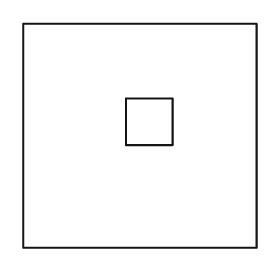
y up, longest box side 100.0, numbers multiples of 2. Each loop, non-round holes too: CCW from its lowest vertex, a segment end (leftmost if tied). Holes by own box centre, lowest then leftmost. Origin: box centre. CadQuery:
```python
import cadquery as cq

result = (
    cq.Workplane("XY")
    .moveTo(-50.0, -48.0)
    .lineTo(50.0, -48.0)
    .lineTo(50.0, 48.0)
    .lineTo(-50.0, 48.0)
    .close()
    .moveTo(-6.0, -4.0)
    .lineTo(14.0, -4.0)
    .lineTo(14.0, 16.0)
    .lineTo(-6.0, 16.0)
    .close()
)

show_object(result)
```